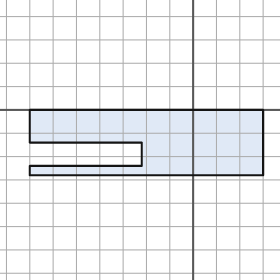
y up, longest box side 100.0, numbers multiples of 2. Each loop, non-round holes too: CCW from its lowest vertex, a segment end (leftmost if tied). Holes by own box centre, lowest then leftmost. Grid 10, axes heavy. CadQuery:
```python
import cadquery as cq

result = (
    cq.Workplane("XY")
    .moveTo(-70.0, -28.0)
    .lineTo(30.0, -28.0)
    .lineTo(30.0, 0.0)
    .lineTo(-70.0, 0.0)
    .lineTo(-70.0, -14.0)
    .lineTo(-22.0, -14.0)
    .lineTo(-22.0, -24.0)
    .lineTo(-70.0, -24.0)
    .close()
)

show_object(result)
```